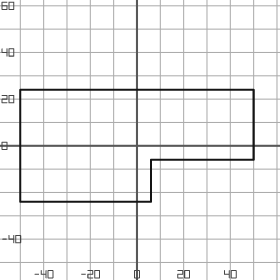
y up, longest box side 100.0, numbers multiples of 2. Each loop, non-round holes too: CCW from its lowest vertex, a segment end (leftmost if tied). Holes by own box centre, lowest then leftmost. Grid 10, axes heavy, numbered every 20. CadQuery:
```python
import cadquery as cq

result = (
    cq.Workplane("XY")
    .moveTo(-50.0, -24.0)
    .lineTo(6.0, -24.0)
    .lineTo(6.0, -6.0)
    .lineTo(50.0, -6.0)
    .lineTo(50.0, 24.0)
    .lineTo(-50.0, 24.0)
    .close()
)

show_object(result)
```